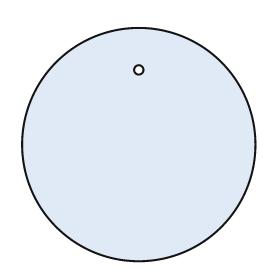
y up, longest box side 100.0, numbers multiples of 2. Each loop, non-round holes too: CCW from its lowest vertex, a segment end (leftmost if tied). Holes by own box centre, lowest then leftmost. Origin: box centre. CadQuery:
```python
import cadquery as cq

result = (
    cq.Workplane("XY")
    .moveTo(0.0, 0.0)
    .circle(50.0)
    .moveTo(0.0, 32.0)
    .circle(2.0)
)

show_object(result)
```